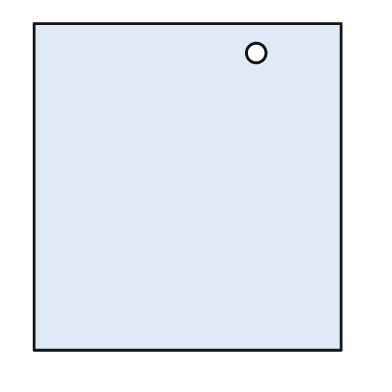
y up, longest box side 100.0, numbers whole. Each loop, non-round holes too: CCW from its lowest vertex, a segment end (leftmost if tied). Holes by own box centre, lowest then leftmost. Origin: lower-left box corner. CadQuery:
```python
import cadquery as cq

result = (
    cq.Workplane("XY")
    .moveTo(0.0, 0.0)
    .lineTo(94.0, 0.0)
    .lineTo(94.0, 100.0)
    .lineTo(0.0, 100.0)
    .close()
    .moveTo(68.0, 91.0)
    .circle(3.0)
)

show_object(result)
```